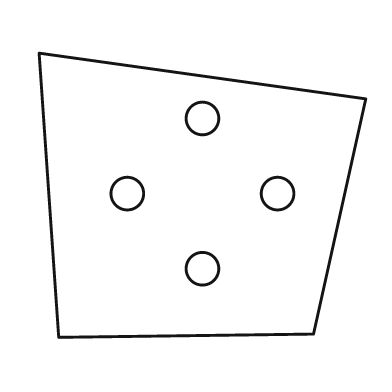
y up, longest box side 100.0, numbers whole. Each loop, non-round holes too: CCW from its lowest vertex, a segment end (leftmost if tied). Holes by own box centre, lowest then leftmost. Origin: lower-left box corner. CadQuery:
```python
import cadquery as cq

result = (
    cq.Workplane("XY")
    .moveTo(6.0, 0.0)
    .lineTo(84.0, 1.0)
    .lineTo(100.0, 73.0)
    .lineTo(0.0, 87.0)
    .close()
    .moveTo(50.0, 21.0)
    .circle(5.0)
    .moveTo(27.0, 44.0)
    .circle(5.0)
    .moveTo(73.0, 44.0)
    .circle(5.0)
    .moveTo(50.0, 67.0)
    .circle(5.0)
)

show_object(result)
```